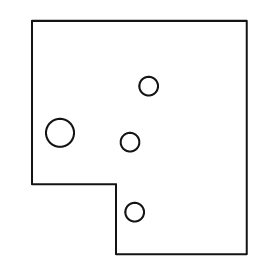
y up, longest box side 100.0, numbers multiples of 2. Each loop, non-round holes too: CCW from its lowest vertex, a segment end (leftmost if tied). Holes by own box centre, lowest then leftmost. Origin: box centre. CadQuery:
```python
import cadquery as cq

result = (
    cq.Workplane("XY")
    .moveTo(-10.0, -50.0)
    .lineTo(46.0, -50.0)
    .lineTo(46.0, 50.0)
    .lineTo(-46.0, 50.0)
    .lineTo(-46.0, -20.0)
    .lineTo(-10.0, -20.0)
    .close()
    .moveTo(-2.0, -32.0)
    .circle(4.0)
    .moveTo(-4.0, -2.0)
    .circle(4.0)
    .moveTo(-34.0, 2.0)
    .circle(6.0)
    .moveTo(4.0, 22.0)
    .circle(4.0)
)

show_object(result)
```